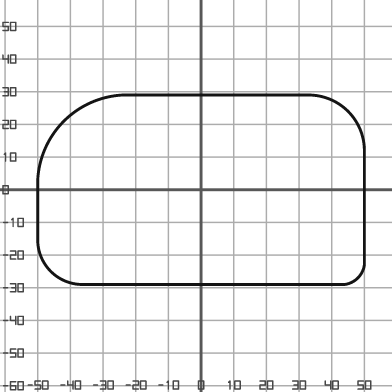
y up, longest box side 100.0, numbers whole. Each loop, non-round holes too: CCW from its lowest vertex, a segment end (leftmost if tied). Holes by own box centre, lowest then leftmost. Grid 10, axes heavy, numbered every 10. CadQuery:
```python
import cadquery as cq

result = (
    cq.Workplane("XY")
    .moveTo(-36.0, -29.0)
    .lineTo(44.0, -29.0)
    .threePointArc((48.0, -27.0), (50.0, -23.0))
    .lineTo(50.0, 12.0)
    .threePointArc((45.0, 24.0), (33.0, 29.0))
    .lineTo(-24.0, 29.0)
    .threePointArc((-42.0, 21.0), (-50.0, 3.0))
    .lineTo(-50.0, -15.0)
    .threePointArc((-46.0, -25.0), (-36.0, -29.0))
    .close()
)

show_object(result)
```